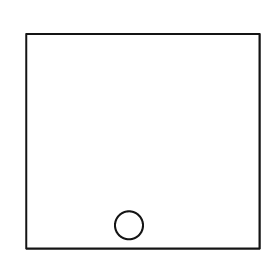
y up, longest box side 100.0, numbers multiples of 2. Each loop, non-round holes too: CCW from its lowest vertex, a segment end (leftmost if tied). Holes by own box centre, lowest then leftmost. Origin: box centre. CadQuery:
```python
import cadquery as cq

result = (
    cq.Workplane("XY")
    .moveTo(-50.0, -46.0)
    .lineTo(50.0, -46.0)
    .lineTo(50.0, 46.0)
    .lineTo(-50.0, 46.0)
    .close()
    .moveTo(-6.0, -36.0)
    .circle(6.0)
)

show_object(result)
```